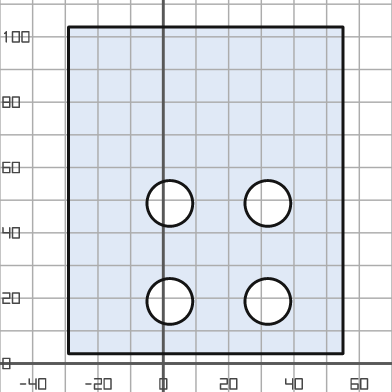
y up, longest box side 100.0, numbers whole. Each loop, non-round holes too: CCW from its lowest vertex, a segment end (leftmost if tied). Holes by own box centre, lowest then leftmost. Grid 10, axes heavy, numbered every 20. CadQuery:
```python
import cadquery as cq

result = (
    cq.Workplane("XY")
    .moveTo(-29.0, 3.0)
    .lineTo(55.0, 3.0)
    .lineTo(55.0, 103.0)
    .lineTo(-29.0, 103.0)
    .close()
    .moveTo(2.0, 19.0)
    .circle(7.0)
    .moveTo(32.0, 19.0)
    .circle(7.0)
    .moveTo(2.0, 49.0)
    .circle(7.0)
    .moveTo(32.0, 49.0)
    .circle(7.0)
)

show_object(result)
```